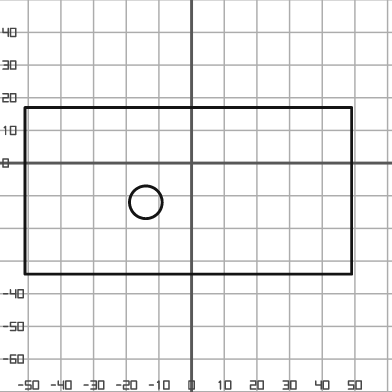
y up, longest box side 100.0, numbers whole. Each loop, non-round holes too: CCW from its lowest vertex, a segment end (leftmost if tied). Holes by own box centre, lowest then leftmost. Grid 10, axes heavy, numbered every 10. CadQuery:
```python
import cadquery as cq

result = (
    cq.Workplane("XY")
    .moveTo(-51.0, -34.0)
    .lineTo(49.0, -34.0)
    .lineTo(49.0, 17.0)
    .lineTo(-51.0, 17.0)
    .close()
    .moveTo(-14.0, -12.0)
    .circle(5.0)
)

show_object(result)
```